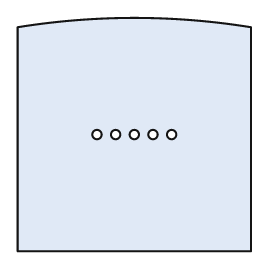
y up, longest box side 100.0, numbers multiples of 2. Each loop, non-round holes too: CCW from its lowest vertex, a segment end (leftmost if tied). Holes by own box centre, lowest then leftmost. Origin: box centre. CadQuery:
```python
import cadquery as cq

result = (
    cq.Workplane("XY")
    .moveTo(-50.0, -50.0)
    .lineTo(50.0, -50.0)
    .lineTo(50.0, 46.0)
    .threePointArc((0.0, 50.0), (-50.0, 46.0))
    .close()
    .moveTo(-16.0, 0.0)
    .circle(2.0)
    .moveTo(-8.0, 0.0)
    .circle(2.0)
    .moveTo(0.0, 0.0)
    .circle(2.0)
    .moveTo(8.0, 0.0)
    .circle(2.0)
    .moveTo(16.0, 0.0)
    .circle(2.0)
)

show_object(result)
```